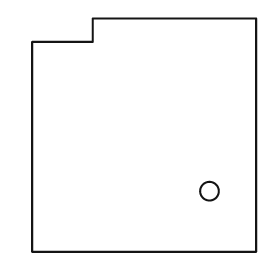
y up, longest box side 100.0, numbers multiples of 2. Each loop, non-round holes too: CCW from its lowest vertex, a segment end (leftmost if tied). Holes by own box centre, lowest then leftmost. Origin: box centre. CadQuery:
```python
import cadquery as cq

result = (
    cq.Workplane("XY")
    .moveTo(-48.0, -50.0)
    .lineTo(48.0, -50.0)
    .lineTo(48.0, 50.0)
    .lineTo(-22.0, 50.0)
    .lineTo(-22.0, 40.0)
    .lineTo(-48.0, 40.0)
    .close()
    .moveTo(28.0, -24.0)
    .circle(4.0)
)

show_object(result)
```